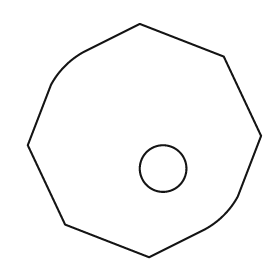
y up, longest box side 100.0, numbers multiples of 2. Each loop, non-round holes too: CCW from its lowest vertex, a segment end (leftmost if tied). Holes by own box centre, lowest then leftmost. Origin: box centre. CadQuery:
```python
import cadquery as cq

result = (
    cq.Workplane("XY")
    .moveTo(2.0, -50.0)
    .lineTo(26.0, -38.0)
    .threePointArc((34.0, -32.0), (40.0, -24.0))
    .lineTo(50.0, 2.0)
    .lineTo(34.0, 36.0)
    .lineTo(-2.0, 50.0)
    .lineTo(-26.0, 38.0)
    .threePointArc((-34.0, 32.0), (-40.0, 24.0))
    .lineTo(-50.0, -2.0)
    .lineTo(-34.0, -36.0)
    .close()
    .moveTo(8.0, -12.0)
    .circle(10.0)
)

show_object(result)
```